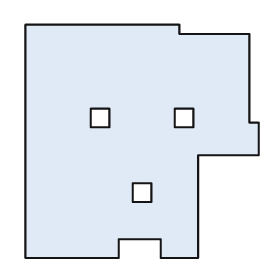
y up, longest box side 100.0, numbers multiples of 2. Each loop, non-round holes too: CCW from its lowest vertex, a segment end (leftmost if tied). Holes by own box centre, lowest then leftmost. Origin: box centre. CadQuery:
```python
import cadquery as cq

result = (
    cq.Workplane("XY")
    .moveTo(-50.0, -50.0)
    .lineTo(-10.0, -50.0)
    .lineTo(-10.0, -42.0)
    .lineTo(8.0, -42.0)
    .lineTo(8.0, -50.0)
    .lineTo(24.0, -50.0)
    .lineTo(24.0, -6.0)
    .lineTo(50.0, -6.0)
    .lineTo(50.0, 8.0)
    .lineTo(46.0, 8.0)
    .lineTo(46.0, 46.0)
    .lineTo(16.0, 46.0)
    .lineTo(16.0, 50.0)
    .lineTo(-50.0, 50.0)
    .close()
    .moveTo(-4.0, -26.0)
    .lineTo(4.0, -26.0)
    .lineTo(4.0, -18.0)
    .lineTo(-4.0, -18.0)
    .close()
    .moveTo(-22.0, 6.0)
    .lineTo(-14.0, 6.0)
    .lineTo(-14.0, 14.0)
    .lineTo(-22.0, 14.0)
    .close()
    .moveTo(14.0, 6.0)
    .lineTo(22.0, 6.0)
    .lineTo(22.0, 14.0)
    .lineTo(14.0, 14.0)
    .close()
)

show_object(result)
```